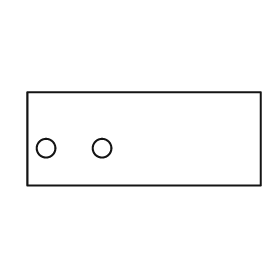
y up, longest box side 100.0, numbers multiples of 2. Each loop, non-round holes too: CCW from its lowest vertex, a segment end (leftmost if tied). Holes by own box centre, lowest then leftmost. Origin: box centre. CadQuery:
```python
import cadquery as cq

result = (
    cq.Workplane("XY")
    .moveTo(-50.0, -20.0)
    .lineTo(50.0, -20.0)
    .lineTo(50.0, 20.0)
    .lineTo(-50.0, 20.0)
    .close()
    .moveTo(-42.0, -4.0)
    .circle(4.0)
    .moveTo(-18.0, -4.0)
    .circle(4.0)
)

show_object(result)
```